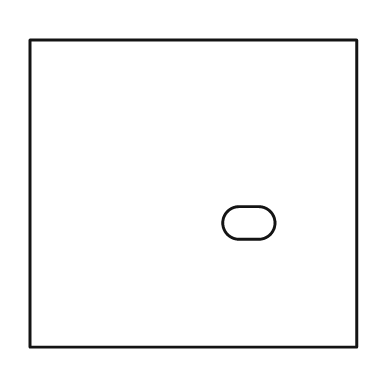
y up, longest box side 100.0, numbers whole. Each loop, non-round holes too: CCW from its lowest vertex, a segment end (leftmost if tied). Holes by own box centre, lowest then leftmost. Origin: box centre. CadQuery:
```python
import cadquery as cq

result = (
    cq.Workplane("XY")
    .moveTo(-50.0, -47.0)
    .lineTo(50.0, -47.0)
    .lineTo(50.0, 47.0)
    .lineTo(-50.0, 47.0)
    .close()
    .moveTo(14.0, -14.0)
    .lineTo(20.0, -14.0)
    .threePointArc((25.0, -9.0), (20.0, -4.0))
    .lineTo(14.0, -4.0)
    .threePointArc((9.0, -9.0), (14.0, -14.0))
    .close()
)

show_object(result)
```